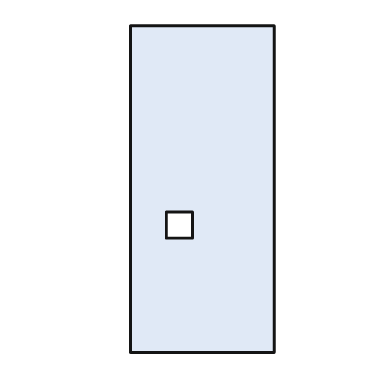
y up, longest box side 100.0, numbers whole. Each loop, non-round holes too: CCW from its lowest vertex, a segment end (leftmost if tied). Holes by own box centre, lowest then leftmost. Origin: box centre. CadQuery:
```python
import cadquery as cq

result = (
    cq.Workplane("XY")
    .moveTo(-22.0, -50.0)
    .lineTo(22.0, -50.0)
    .lineTo(22.0, 50.0)
    .lineTo(-22.0, 50.0)
    .close()
    .moveTo(-11.0, -15.0)
    .lineTo(-3.0, -15.0)
    .lineTo(-3.0, -7.0)
    .lineTo(-11.0, -7.0)
    .close()
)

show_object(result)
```